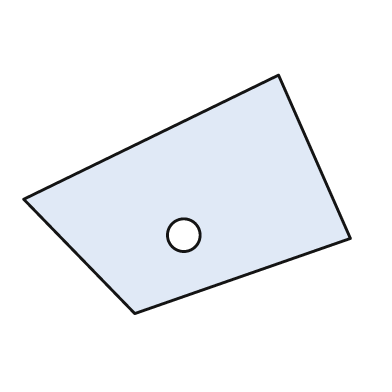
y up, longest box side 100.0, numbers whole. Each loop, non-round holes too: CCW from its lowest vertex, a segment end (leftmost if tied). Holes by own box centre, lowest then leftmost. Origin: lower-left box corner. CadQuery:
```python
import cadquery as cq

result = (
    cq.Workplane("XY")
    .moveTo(34.0, 0.0)
    .lineTo(100.0, 23.0)
    .lineTo(78.0, 73.0)
    .lineTo(0.0, 35.0)
    .close()
    .moveTo(49.0, 24.0)
    .circle(5.0)
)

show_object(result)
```